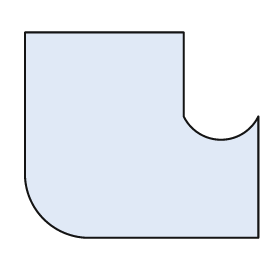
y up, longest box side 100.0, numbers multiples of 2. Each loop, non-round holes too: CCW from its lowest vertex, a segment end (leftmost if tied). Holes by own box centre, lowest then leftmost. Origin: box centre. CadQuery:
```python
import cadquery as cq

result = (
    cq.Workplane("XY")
    .moveTo(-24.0, -44.0)
    .lineTo(50.0, -44.0)
    .lineTo(50.0, 8.0)
    .threePointArc((34.0, -2.0), (18.0, 8.0))
    .lineTo(18.0, 44.0)
    .lineTo(-50.0, 44.0)
    .lineTo(-50.0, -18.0)
    .threePointArc((-42.0, -36.0), (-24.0, -44.0))
    .close()
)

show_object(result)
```